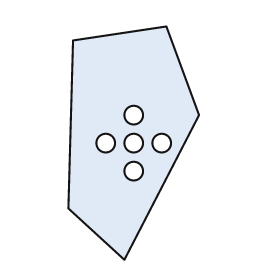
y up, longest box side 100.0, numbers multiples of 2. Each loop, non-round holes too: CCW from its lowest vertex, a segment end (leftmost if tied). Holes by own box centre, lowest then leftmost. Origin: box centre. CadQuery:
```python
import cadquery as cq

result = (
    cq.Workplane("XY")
    .moveTo(-4.0, -50.0)
    .lineTo(28.0, 12.0)
    .lineTo(14.0, 50.0)
    .lineTo(-26.0, 44.0)
    .lineTo(-28.0, -28.0)
    .close()
    .moveTo(0.0, -12.0)
    .circle(4.0)
    .moveTo(-12.0, 0.0)
    .circle(4.0)
    .moveTo(0.0, 0.0)
    .circle(4.0)
    .moveTo(12.0, 0.0)
    .circle(4.0)
    .moveTo(0.0, 12.0)
    .circle(4.0)
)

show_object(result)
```